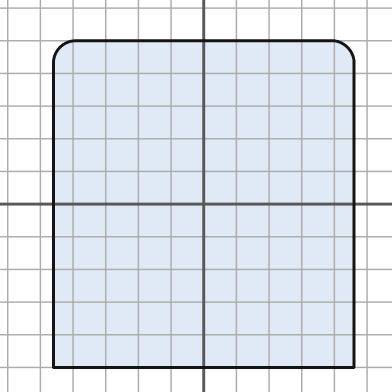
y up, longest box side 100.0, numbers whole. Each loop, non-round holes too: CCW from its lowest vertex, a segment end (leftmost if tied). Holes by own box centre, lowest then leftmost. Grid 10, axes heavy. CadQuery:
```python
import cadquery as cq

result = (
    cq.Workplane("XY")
    .moveTo(-46.0, -50.0)
    .lineTo(46.0, -50.0)
    .lineTo(46.0, 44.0)
    .threePointArc((44.0, 48.0), (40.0, 50.0))
    .lineTo(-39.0, 50.0)
    .threePointArc((-44.0, 48.0), (-46.0, 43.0))
    .close()
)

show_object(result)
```